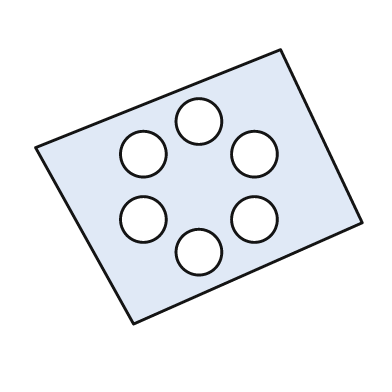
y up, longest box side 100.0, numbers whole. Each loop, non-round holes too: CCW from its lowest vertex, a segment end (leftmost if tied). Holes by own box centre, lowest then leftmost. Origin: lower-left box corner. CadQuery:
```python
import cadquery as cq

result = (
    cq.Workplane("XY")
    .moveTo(30.0, 0.0)
    .lineTo(100.0, 31.0)
    .lineTo(75.0, 84.0)
    .lineTo(0.0, 54.0)
    .close()
    .moveTo(50.0, 22.0)
    .circle(7.0)
    .moveTo(33.0, 32.0)
    .circle(7.0)
    .moveTo(67.0, 32.0)
    .circle(7.0)
    .moveTo(33.0, 52.0)
    .circle(7.0)
    .moveTo(67.0, 52.0)
    .circle(7.0)
    .moveTo(50.0, 62.0)
    .circle(7.0)
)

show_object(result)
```